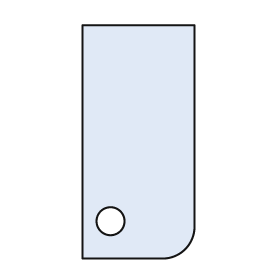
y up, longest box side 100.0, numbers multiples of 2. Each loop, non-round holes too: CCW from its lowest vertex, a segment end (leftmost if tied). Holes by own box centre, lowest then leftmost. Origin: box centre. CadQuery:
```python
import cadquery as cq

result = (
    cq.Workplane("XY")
    .moveTo(-24.0, -50.0)
    .lineTo(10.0, -50.0)
    .threePointArc((20.0, -46.0), (24.0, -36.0))
    .lineTo(24.0, 50.0)
    .lineTo(-24.0, 50.0)
    .close()
    .moveTo(-12.0, -34.0)
    .circle(6.0)
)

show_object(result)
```